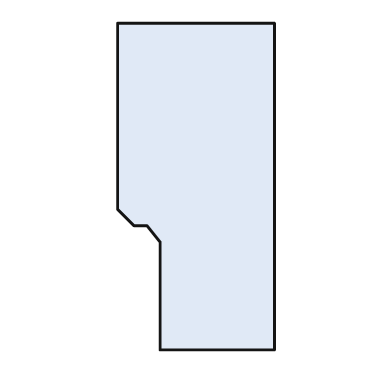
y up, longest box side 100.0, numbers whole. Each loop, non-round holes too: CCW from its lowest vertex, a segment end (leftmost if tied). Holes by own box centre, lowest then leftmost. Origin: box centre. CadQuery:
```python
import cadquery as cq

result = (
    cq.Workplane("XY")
    .moveTo(-11.0, -50.0)
    .lineTo(24.0, -50.0)
    .lineTo(24.0, 50.0)
    .lineTo(-24.0, 50.0)
    .lineTo(-24.0, -7.0)
    .lineTo(-19.0, -12.0)
    .lineTo(-15.0, -12.0)
    .lineTo(-11.0, -17.0)
    .close()
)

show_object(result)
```